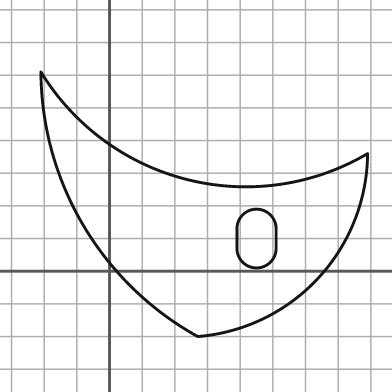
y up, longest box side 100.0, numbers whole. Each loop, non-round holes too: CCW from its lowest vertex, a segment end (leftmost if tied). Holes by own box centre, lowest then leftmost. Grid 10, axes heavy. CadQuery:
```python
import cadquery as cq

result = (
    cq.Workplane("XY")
    .moveTo(27.0, -20.0)
    .threePointArc((64.0, -2.0), (79.0, 36.0))
    .threePointArc((24.0, 28.0), (-21.0, 61.0))
    .threePointArc((-8.0, 14.0), (27.0, -20.0))
    .close()
    .moveTo(39.0, 7.0)
    .threePointArc((45.0, 1.0), (51.0, 7.0))
    .lineTo(51.0, 13.0)
    .threePointArc((45.0, 19.0), (39.0, 13.0))
    .close()
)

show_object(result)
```